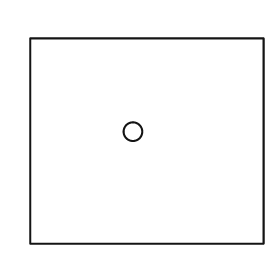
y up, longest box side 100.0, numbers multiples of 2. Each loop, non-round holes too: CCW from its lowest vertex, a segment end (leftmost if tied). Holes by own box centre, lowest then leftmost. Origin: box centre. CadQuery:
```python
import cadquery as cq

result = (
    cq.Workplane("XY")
    .moveTo(-50.0, -44.0)
    .lineTo(50.0, -44.0)
    .lineTo(50.0, 44.0)
    .lineTo(-50.0, 44.0)
    .close()
    .moveTo(-6.0, 4.0)
    .circle(4.0)
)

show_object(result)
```